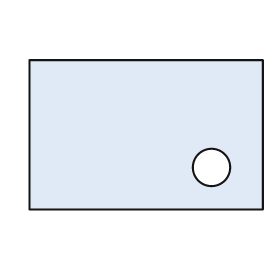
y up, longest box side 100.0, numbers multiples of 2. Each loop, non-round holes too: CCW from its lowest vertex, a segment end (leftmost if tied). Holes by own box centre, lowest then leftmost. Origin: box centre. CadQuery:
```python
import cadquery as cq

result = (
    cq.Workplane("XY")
    .moveTo(-50.0, -32.0)
    .lineTo(50.0, -32.0)
    .lineTo(50.0, 32.0)
    .lineTo(-50.0, 32.0)
    .close()
    .moveTo(28.0, -14.0)
    .circle(8.0)
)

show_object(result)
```